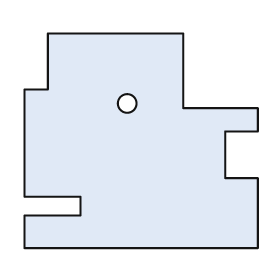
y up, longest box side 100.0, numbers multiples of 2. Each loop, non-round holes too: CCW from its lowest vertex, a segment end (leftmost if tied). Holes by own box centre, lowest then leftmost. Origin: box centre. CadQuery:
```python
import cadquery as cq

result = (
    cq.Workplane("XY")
    .moveTo(-50.0, -46.0)
    .lineTo(50.0, -46.0)
    .lineTo(50.0, -16.0)
    .lineTo(36.0, -16.0)
    .lineTo(36.0, 4.0)
    .lineTo(50.0, 4.0)
    .lineTo(50.0, 14.0)
    .lineTo(18.0, 14.0)
    .lineTo(18.0, 46.0)
    .lineTo(-40.0, 46.0)
    .lineTo(-40.0, 22.0)
    .lineTo(-50.0, 22.0)
    .lineTo(-50.0, -24.0)
    .lineTo(-26.0, -24.0)
    .lineTo(-26.0, -32.0)
    .lineTo(-50.0, -32.0)
    .close()
    .moveTo(-6.0, 16.0)
    .circle(4.0)
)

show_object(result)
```